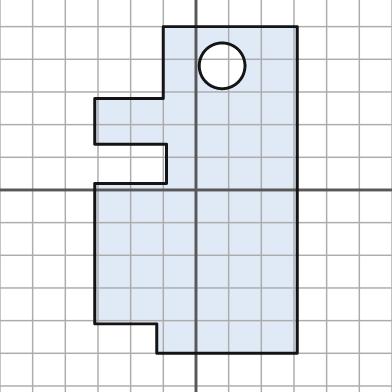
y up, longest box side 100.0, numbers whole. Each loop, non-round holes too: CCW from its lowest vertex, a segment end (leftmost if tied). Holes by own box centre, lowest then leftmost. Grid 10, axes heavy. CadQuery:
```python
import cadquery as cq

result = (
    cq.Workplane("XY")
    .moveTo(-12.0, -50.0)
    .lineTo(31.0, -50.0)
    .lineTo(31.0, 50.0)
    .lineTo(-10.0, 50.0)
    .lineTo(-10.0, 28.0)
    .lineTo(-31.0, 28.0)
    .lineTo(-31.0, 14.0)
    .lineTo(-9.0, 14.0)
    .lineTo(-9.0, 2.0)
    .lineTo(-31.0, 2.0)
    .lineTo(-31.0, -41.0)
    .lineTo(-12.0, -41.0)
    .close()
    .moveTo(8.0, 38.0)
    .circle(7.0)
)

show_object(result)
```